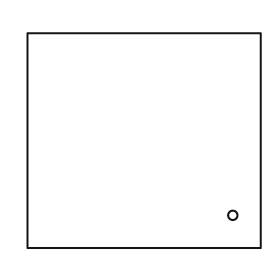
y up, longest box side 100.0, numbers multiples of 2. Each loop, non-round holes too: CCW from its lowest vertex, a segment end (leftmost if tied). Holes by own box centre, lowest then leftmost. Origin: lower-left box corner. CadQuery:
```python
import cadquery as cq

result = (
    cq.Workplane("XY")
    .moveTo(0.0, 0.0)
    .lineTo(100.0, 0.0)
    .lineTo(100.0, 92.0)
    .lineTo(0.0, 92.0)
    .close()
    .moveTo(88.0, 14.0)
    .circle(2.0)
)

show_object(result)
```